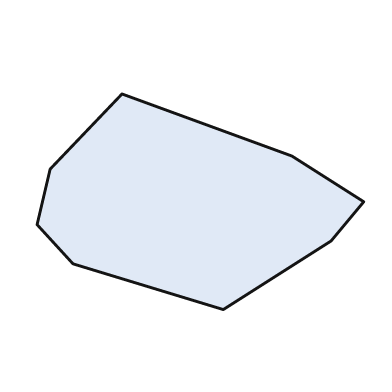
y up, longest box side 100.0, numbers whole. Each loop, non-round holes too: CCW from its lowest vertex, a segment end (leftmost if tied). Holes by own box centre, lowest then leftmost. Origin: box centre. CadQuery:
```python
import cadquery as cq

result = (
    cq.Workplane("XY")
    .moveTo(7.0, -33.0)
    .lineTo(40.0, -12.0)
    .lineTo(50.0, 0.0)
    .lineTo(28.0, 14.0)
    .lineTo(-24.0, 33.0)
    .lineTo(-46.0, 10.0)
    .lineTo(-50.0, -7.0)
    .lineTo(-39.0, -19.0)
    .close()
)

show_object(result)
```